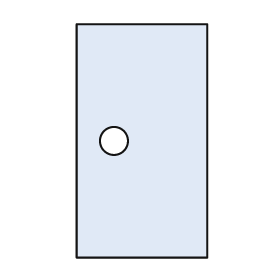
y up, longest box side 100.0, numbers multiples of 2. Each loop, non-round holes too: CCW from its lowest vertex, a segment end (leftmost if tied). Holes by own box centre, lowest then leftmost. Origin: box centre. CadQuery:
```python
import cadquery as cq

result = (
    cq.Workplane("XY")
    .moveTo(-28.0, -50.0)
    .lineTo(28.0, -50.0)
    .lineTo(28.0, 50.0)
    .lineTo(-28.0, 50.0)
    .close()
    .moveTo(-12.0, 0.0)
    .circle(6.0)
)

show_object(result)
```